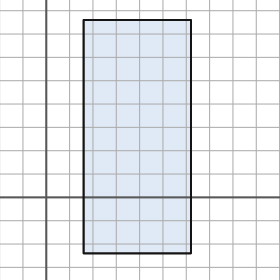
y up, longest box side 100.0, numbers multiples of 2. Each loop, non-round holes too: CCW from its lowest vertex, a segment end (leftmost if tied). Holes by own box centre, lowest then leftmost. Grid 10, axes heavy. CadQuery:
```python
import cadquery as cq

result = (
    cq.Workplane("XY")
    .moveTo(16.0, -24.0)
    .lineTo(62.0, -24.0)
    .lineTo(62.0, 76.0)
    .lineTo(16.0, 76.0)
    .close()
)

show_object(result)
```